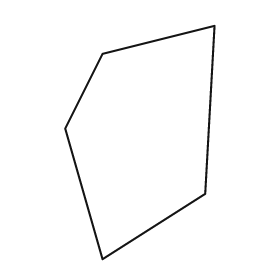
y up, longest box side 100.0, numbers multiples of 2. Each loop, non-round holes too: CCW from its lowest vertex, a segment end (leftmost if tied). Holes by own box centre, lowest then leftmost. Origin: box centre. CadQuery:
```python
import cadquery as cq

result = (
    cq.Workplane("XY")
    .moveTo(-16.0, -50.0)
    .lineTo(28.0, -22.0)
    .lineTo(32.0, 50.0)
    .lineTo(-16.0, 38.0)
    .lineTo(-32.0, 6.0)
    .close()
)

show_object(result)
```